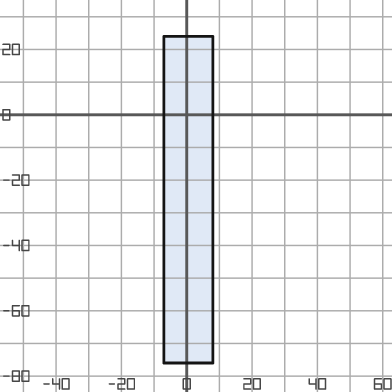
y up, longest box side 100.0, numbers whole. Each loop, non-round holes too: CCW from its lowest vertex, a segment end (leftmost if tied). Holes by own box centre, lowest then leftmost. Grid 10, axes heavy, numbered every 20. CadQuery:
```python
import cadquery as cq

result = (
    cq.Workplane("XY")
    .moveTo(-7.0, -76.0)
    .lineTo(8.0, -76.0)
    .lineTo(8.0, 24.0)
    .lineTo(-7.0, 24.0)
    .close()
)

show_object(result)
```